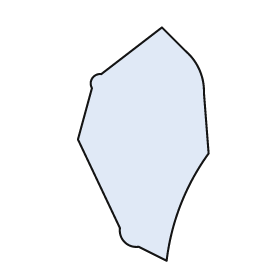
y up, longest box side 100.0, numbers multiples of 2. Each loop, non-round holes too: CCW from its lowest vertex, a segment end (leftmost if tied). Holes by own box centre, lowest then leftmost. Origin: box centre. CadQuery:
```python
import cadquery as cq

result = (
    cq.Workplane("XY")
    .moveTo(10.0, -50.0)
    .threePointArc((16.0, -26.0), (28.0, -4.0))
    .lineTo(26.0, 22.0)
    .threePointArc((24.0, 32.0), (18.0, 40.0))
    .lineTo(8.0, 50.0)
    .lineTo(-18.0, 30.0)
    .threePointArc((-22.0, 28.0), (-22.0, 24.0))
    .lineTo(-28.0, 2.0)
    .lineTo(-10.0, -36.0)
    .threePointArc((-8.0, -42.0), (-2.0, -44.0))
    .close()
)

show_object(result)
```